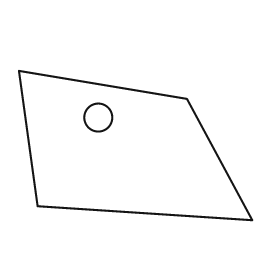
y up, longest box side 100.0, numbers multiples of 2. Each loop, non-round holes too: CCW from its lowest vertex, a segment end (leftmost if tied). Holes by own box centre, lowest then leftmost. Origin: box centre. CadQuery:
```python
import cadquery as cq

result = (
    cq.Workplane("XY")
    .moveTo(50.0, -32.0)
    .lineTo(22.0, 20.0)
    .lineTo(-50.0, 32.0)
    .lineTo(-42.0, -26.0)
    .close()
    .moveTo(-16.0, 12.0)
    .circle(6.0)
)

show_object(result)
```